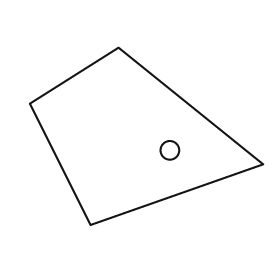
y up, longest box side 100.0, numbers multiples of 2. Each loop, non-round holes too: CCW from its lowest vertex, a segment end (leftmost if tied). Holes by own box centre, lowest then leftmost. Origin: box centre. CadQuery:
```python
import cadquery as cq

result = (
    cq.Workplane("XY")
    .moveTo(-24.0, -38.0)
    .lineTo(50.0, -12.0)
    .lineTo(-12.0, 38.0)
    .lineTo(-50.0, 14.0)
    .close()
    .moveTo(10.0, -6.0)
    .circle(4.0)
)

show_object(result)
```